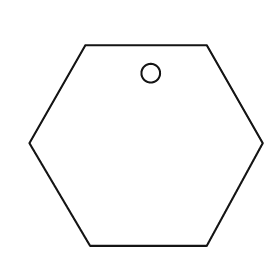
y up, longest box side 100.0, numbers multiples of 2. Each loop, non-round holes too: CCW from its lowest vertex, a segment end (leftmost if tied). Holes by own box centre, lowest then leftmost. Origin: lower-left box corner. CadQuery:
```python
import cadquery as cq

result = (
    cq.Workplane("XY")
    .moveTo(26.0, 0.0)
    .lineTo(76.0, 0.0)
    .lineTo(100.0, 44.0)
    .lineTo(76.0, 86.0)
    .lineTo(24.0, 86.0)
    .lineTo(0.0, 44.0)
    .close()
    .moveTo(52.0, 74.0)
    .circle(4.0)
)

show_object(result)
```